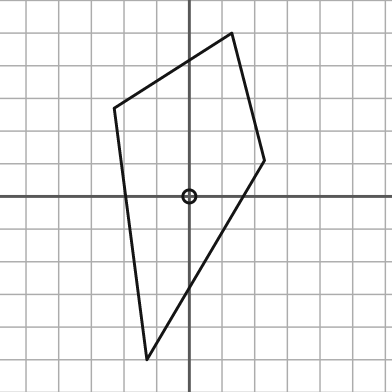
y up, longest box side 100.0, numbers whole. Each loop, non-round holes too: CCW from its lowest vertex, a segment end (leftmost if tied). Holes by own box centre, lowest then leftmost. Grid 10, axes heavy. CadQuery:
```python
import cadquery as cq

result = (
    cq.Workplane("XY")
    .moveTo(-13.0, -50.0)
    .lineTo(23.0, 11.0)
    .lineTo(13.0, 50.0)
    .lineTo(-23.0, 27.0)
    .close()
    .moveTo(0.0, 0.0)
    .circle(2.0)
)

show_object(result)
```